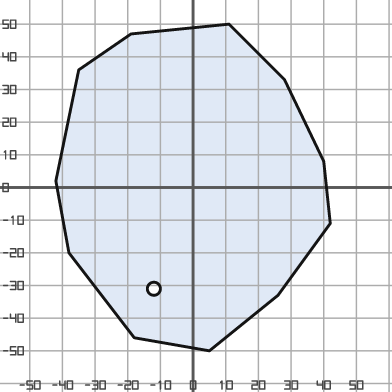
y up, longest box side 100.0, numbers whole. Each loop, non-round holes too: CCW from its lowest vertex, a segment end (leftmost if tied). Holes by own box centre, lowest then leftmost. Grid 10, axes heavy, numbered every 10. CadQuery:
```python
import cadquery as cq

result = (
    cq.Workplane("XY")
    .moveTo(5.0, -50.0)
    .lineTo(26.0, -33.0)
    .lineTo(42.0, -11.0)
    .lineTo(40.0, 8.0)
    .lineTo(28.0, 33.0)
    .lineTo(11.0, 50.0)
    .lineTo(-19.0, 47.0)
    .lineTo(-35.0, 36.0)
    .lineTo(-42.0, 2.0)
    .lineTo(-38.0, -20.0)
    .lineTo(-18.0, -46.0)
    .close()
    .moveTo(-12.0, -31.0)
    .circle(2.0)
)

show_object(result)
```